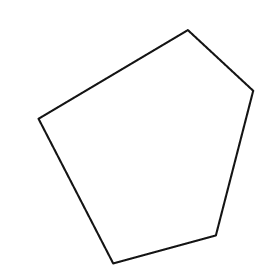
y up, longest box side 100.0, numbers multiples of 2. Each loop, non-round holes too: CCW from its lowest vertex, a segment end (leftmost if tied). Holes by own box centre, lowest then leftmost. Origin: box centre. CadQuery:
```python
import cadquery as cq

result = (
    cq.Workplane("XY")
    .moveTo(-14.0, -50.0)
    .lineTo(30.0, -38.0)
    .lineTo(46.0, 24.0)
    .lineTo(18.0, 50.0)
    .lineTo(-46.0, 12.0)
    .close()
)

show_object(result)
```